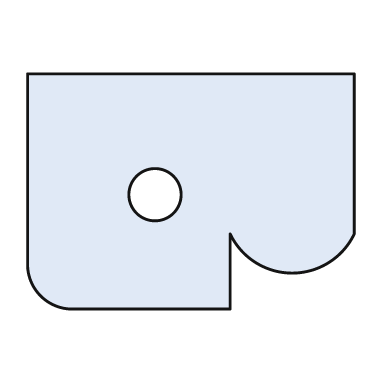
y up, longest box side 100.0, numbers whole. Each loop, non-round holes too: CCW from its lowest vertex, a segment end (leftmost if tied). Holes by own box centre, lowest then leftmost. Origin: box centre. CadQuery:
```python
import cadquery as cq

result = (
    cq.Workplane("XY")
    .moveTo(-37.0, -36.0)
    .lineTo(12.0, -36.0)
    .lineTo(12.0, -13.0)
    .threePointArc((31.0, -25.0), (50.0, -13.0))
    .lineTo(50.0, 36.0)
    .lineTo(-50.0, 36.0)
    .lineTo(-50.0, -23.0)
    .threePointArc((-46.0, -32.0), (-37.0, -36.0))
    .close()
    .moveTo(-11.0, -1.0)
    .circle(8.0)
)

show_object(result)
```